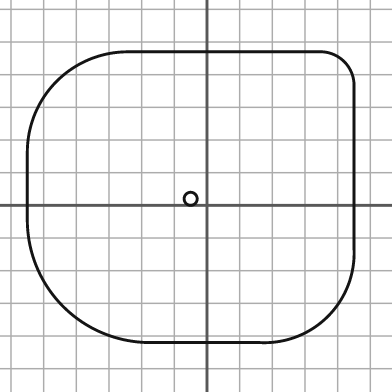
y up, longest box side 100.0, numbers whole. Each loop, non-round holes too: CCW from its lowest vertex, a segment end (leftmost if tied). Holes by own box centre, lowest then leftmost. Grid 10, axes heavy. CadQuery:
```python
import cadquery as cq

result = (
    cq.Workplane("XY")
    .moveTo(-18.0, -42.0)
    .lineTo(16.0, -42.0)
    .threePointArc((37.0, -34.0), (45.0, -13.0))
    .lineTo(45.0, 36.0)
    .threePointArc((42.0, 44.0), (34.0, 47.0))
    .lineTo(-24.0, 47.0)
    .threePointArc((-46.0, 38.0), (-55.0, 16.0))
    .lineTo(-55.0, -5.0)
    .threePointArc((-44.0, -31.0), (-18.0, -42.0))
    .close()
    .moveTo(-5.0, 2.0)
    .circle(2.0)
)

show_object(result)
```